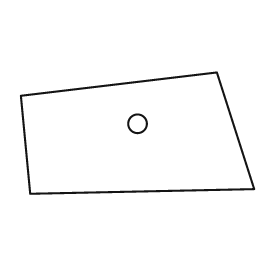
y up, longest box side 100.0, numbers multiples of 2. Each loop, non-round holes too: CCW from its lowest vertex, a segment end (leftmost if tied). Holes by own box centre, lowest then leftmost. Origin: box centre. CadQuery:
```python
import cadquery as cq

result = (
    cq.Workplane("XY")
    .moveTo(-46.0, -26.0)
    .lineTo(50.0, -24.0)
    .lineTo(34.0, 26.0)
    .lineTo(-50.0, 16.0)
    .close()
    .moveTo(0.0, 4.0)
    .circle(4.0)
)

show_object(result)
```